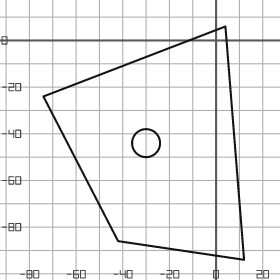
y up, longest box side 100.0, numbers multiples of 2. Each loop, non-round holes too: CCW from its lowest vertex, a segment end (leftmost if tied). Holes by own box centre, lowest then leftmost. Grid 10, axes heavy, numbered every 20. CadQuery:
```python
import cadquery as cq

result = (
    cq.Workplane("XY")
    .moveTo(12.0, -94.0)
    .lineTo(4.0, 6.0)
    .lineTo(-74.0, -24.0)
    .lineTo(-42.0, -86.0)
    .close()
    .moveTo(-30.0, -44.0)
    .circle(6.0)
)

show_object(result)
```